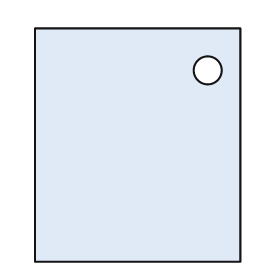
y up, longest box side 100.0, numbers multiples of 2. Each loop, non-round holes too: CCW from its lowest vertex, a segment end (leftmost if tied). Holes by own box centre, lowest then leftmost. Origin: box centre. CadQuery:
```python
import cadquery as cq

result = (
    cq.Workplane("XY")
    .moveTo(-44.0, -50.0)
    .lineTo(44.0, -50.0)
    .lineTo(44.0, 50.0)
    .lineTo(-44.0, 50.0)
    .close()
    .moveTo(30.0, 32.0)
    .circle(6.0)
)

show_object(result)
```